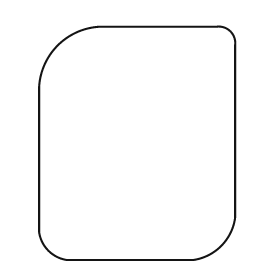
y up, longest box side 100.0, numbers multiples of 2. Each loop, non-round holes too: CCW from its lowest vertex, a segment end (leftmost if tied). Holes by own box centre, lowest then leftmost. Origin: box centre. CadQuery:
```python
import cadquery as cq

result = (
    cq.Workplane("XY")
    .moveTo(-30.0, -50.0)
    .lineTo(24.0, -50.0)
    .threePointArc((36.0, -44.0), (42.0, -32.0))
    .lineTo(42.0, 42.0)
    .threePointArc((40.0, 48.0), (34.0, 50.0))
    .lineTo(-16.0, 50.0)
    .threePointArc((-34.0, 42.0), (-42.0, 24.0))
    .lineTo(-42.0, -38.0)
    .threePointArc((-38.0, -46.0), (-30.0, -50.0))
    .close()
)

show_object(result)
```